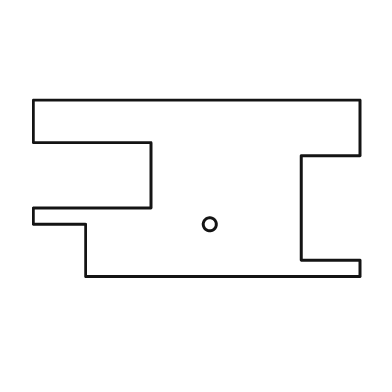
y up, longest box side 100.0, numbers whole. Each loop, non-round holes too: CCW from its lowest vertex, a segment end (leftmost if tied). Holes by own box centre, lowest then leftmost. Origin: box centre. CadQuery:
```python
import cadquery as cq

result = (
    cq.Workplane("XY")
    .moveTo(-34.0, -27.0)
    .lineTo(50.0, -27.0)
    .lineTo(50.0, -22.0)
    .lineTo(32.0, -22.0)
    .lineTo(32.0, 10.0)
    .lineTo(50.0, 10.0)
    .lineTo(50.0, 27.0)
    .lineTo(-50.0, 27.0)
    .lineTo(-50.0, 14.0)
    .lineTo(-14.0, 14.0)
    .lineTo(-14.0, -6.0)
    .lineTo(-50.0, -6.0)
    .lineTo(-50.0, -11.0)
    .lineTo(-34.0, -11.0)
    .close()
    .moveTo(4.0, -11.0)
    .circle(2.0)
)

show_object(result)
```